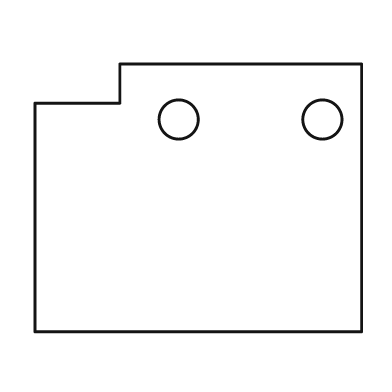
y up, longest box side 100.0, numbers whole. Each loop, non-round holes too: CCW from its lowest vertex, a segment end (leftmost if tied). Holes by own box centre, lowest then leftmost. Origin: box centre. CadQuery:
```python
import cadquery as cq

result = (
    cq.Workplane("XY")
    .moveTo(-50.0, -41.0)
    .lineTo(50.0, -41.0)
    .lineTo(50.0, 41.0)
    .lineTo(-24.0, 41.0)
    .lineTo(-24.0, 29.0)
    .lineTo(-50.0, 29.0)
    .close()
    .moveTo(-6.0, 24.0)
    .circle(6.0)
    .moveTo(38.0, 24.0)
    .circle(6.0)
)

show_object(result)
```